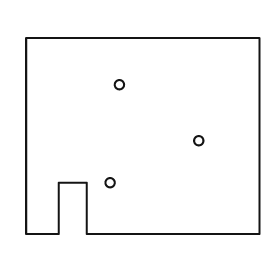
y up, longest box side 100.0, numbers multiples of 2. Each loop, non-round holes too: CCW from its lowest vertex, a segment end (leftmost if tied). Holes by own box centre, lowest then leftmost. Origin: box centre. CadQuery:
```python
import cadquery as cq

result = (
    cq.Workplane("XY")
    .moveTo(-50.0, -42.0)
    .lineTo(-36.0, -42.0)
    .lineTo(-36.0, -20.0)
    .lineTo(-24.0, -20.0)
    .lineTo(-24.0, -42.0)
    .lineTo(50.0, -42.0)
    .lineTo(50.0, 42.0)
    .lineTo(-50.0, 42.0)
    .close()
    .moveTo(-14.0, -20.0)
    .circle(2.0)
    .moveTo(24.0, -2.0)
    .circle(2.0)
    .moveTo(-10.0, 22.0)
    .circle(2.0)
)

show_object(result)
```